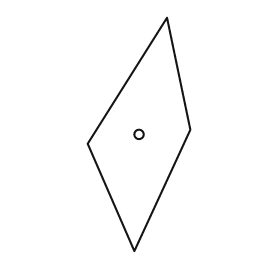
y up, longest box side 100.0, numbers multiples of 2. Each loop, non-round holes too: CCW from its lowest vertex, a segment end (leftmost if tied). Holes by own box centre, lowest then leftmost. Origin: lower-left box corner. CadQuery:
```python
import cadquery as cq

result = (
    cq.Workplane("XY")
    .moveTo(20.0, 0.0)
    .lineTo(44.0, 52.0)
    .lineTo(34.0, 100.0)
    .lineTo(0.0, 46.0)
    .close()
    .moveTo(22.0, 50.0)
    .circle(2.0)
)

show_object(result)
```